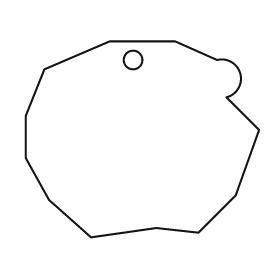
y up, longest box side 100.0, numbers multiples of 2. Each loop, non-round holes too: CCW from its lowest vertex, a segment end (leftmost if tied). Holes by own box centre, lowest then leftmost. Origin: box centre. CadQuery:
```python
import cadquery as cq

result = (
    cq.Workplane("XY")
    .moveTo(-22.0, -42.0)
    .lineTo(6.0, -38.0)
    .lineTo(24.0, -40.0)
    .lineTo(40.0, -24.0)
    .lineTo(50.0, 4.0)
    .lineTo(36.0, 18.0)
    .threePointArc((42.0, 28.0), (32.0, 34.0))
    .lineTo(14.0, 42.0)
    .lineTo(-14.0, 42.0)
    .lineTo(-42.0, 30.0)
    .lineTo(-50.0, 10.0)
    .lineTo(-50.0, -8.0)
    .lineTo(-40.0, -26.0)
    .close()
    .moveTo(-4.0, 34.0)
    .circle(4.0)
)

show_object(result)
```